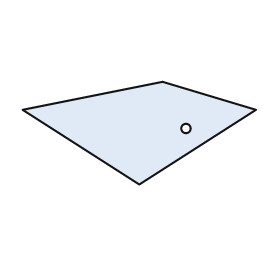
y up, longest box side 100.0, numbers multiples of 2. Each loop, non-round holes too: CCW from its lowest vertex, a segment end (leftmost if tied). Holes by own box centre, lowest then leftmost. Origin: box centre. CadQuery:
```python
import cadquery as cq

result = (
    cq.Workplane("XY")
    .moveTo(0.0, -22.0)
    .lineTo(50.0, 10.0)
    .lineTo(10.0, 22.0)
    .lineTo(-50.0, 10.0)
    .close()
    .moveTo(20.0, 2.0)
    .circle(2.0)
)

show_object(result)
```